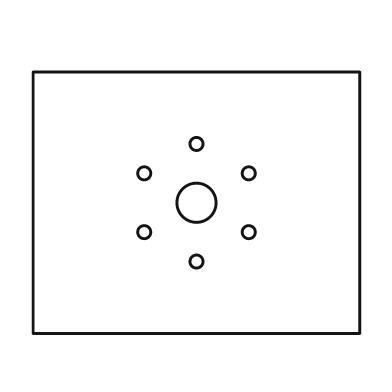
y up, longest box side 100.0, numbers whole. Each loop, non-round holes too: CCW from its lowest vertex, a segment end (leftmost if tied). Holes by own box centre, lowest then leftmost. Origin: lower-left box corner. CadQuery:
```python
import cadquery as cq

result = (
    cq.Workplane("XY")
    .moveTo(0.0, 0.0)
    .lineTo(100.0, 0.0)
    .lineTo(100.0, 80.0)
    .lineTo(0.0, 80.0)
    .close()
    .moveTo(50.0, 22.0)
    .circle(2.0)
    .moveTo(34.0, 31.0)
    .circle(2.0)
    .moveTo(66.0, 31.0)
    .circle(2.0)
    .moveTo(50.0, 40.0)
    .circle(6.0)
    .moveTo(34.0, 49.0)
    .circle(2.0)
    .moveTo(66.0, 49.0)
    .circle(2.0)
    .moveTo(50.0, 58.0)
    .circle(2.0)
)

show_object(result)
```